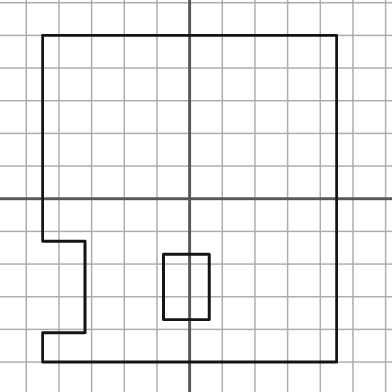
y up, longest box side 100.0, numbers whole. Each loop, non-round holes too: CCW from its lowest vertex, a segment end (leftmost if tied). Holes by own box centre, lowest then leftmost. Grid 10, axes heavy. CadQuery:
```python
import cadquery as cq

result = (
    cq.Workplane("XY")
    .moveTo(-45.0, -50.0)
    .lineTo(45.0, -50.0)
    .lineTo(45.0, 50.0)
    .lineTo(-45.0, 50.0)
    .lineTo(-45.0, -13.0)
    .lineTo(-32.0, -13.0)
    .lineTo(-32.0, -41.0)
    .lineTo(-45.0, -41.0)
    .close()
    .moveTo(-8.0, -37.0)
    .lineTo(6.0, -37.0)
    .lineTo(6.0, -17.0)
    .lineTo(-8.0, -17.0)
    .close()
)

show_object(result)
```